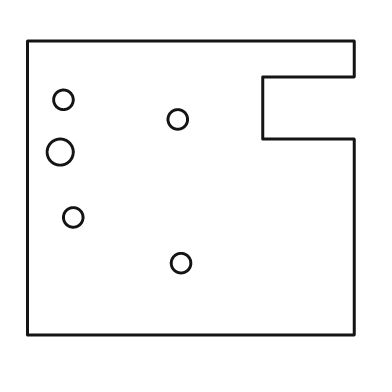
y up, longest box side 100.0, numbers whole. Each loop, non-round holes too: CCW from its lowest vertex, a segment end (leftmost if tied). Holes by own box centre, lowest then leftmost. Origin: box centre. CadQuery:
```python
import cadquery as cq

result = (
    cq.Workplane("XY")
    .moveTo(-50.0, -45.0)
    .lineTo(50.0, -45.0)
    .lineTo(50.0, 15.0)
    .lineTo(22.0, 15.0)
    .lineTo(22.0, 34.0)
    .lineTo(50.0, 34.0)
    .lineTo(50.0, 45.0)
    .lineTo(-50.0, 45.0)
    .close()
    .moveTo(-3.0, -23.0)
    .circle(3.0)
    .moveTo(-36.0, -9.0)
    .circle(3.0)
    .moveTo(-40.0, 11.0)
    .circle(4.0)
    .moveTo(-4.0, 21.0)
    .circle(3.0)
    .moveTo(-39.0, 27.0)
    .circle(3.0)
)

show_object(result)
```